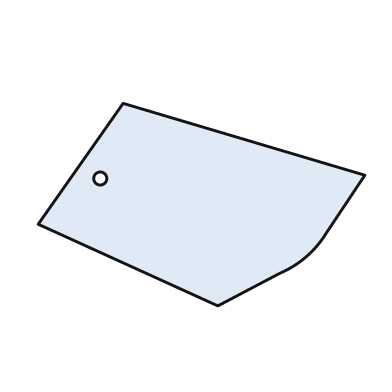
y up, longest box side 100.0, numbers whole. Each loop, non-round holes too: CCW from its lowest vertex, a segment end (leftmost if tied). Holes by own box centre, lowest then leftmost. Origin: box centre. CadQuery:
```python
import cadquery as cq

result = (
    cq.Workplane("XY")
    .moveTo(5.0, -31.0)
    .lineTo(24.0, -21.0)
    .threePointArc((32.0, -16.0), (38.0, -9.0))
    .lineTo(50.0, 9.0)
    .lineTo(-24.0, 31.0)
    .lineTo(-50.0, -6.0)
    .close()
    .moveTo(-31.0, 8.0)
    .circle(2.0)
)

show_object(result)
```